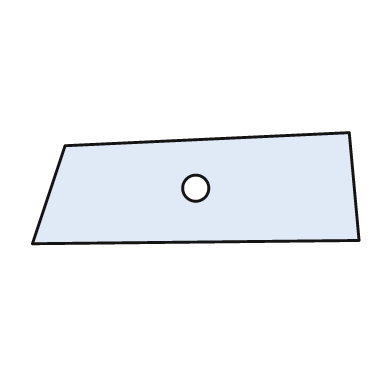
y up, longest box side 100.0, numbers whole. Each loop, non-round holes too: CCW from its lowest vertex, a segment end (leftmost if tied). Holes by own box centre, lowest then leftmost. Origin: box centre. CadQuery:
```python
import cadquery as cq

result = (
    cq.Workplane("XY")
    .moveTo(-50.0, -17.0)
    .lineTo(50.0, -16.0)
    .lineTo(47.0, 17.0)
    .lineTo(-40.0, 13.0)
    .close()
    .moveTo(0.0, 0.0)
    .circle(4.0)
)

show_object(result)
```